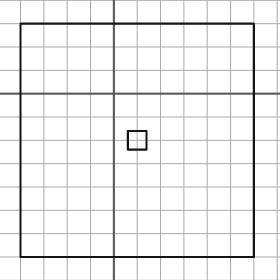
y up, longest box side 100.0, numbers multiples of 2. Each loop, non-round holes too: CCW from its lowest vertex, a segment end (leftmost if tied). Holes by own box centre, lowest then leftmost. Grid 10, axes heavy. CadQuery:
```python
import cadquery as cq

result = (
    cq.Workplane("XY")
    .moveTo(-40.0, -70.0)
    .lineTo(60.0, -70.0)
    .lineTo(60.0, 30.0)
    .lineTo(-40.0, 30.0)
    .close()
    .moveTo(6.0, -24.0)
    .lineTo(14.0, -24.0)
    .lineTo(14.0, -16.0)
    .lineTo(6.0, -16.0)
    .close()
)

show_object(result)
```